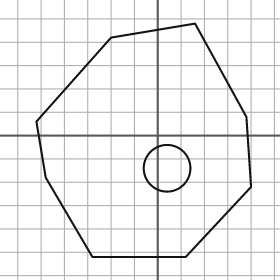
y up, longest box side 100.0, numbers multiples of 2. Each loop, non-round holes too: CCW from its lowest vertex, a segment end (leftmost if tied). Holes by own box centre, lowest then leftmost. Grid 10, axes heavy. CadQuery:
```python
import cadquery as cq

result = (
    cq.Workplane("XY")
    .moveTo(-28.0, -52.0)
    .lineTo(12.0, -52.0)
    .lineTo(40.0, -22.0)
    .lineTo(38.0, 8.0)
    .lineTo(16.0, 48.0)
    .lineTo(-20.0, 42.0)
    .lineTo(-52.0, 6.0)
    .lineTo(-48.0, -18.0)
    .close()
    .moveTo(4.0, -14.0)
    .circle(10.0)
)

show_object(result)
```